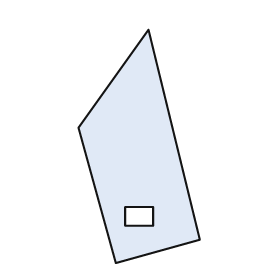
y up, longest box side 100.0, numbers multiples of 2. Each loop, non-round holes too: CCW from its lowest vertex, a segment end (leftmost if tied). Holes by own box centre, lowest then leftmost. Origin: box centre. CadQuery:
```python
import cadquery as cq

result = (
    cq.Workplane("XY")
    .moveTo(-10.0, -50.0)
    .lineTo(26.0, -40.0)
    .lineTo(4.0, 50.0)
    .lineTo(-26.0, 8.0)
    .close()
    .moveTo(-6.0, -34.0)
    .lineTo(6.0, -34.0)
    .lineTo(6.0, -26.0)
    .lineTo(-6.0, -26.0)
    .close()
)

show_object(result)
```